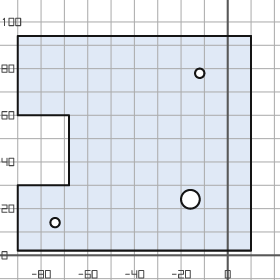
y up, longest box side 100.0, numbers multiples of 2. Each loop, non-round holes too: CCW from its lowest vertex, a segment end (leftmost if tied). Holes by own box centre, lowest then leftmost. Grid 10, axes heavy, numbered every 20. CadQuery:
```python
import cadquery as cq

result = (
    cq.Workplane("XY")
    .moveTo(-90.0, 2.0)
    .lineTo(10.0, 2.0)
    .lineTo(10.0, 94.0)
    .lineTo(-90.0, 94.0)
    .lineTo(-90.0, 60.0)
    .lineTo(-68.0, 60.0)
    .lineTo(-68.0, 30.0)
    .lineTo(-90.0, 30.0)
    .close()
    .moveTo(-74.0, 14.0)
    .circle(2.0)
    .moveTo(-16.0, 24.0)
    .circle(4.0)
    .moveTo(-12.0, 78.0)
    .circle(2.0)
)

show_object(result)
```